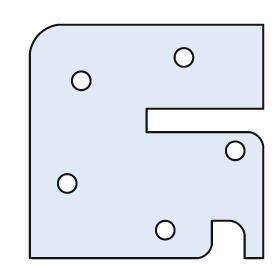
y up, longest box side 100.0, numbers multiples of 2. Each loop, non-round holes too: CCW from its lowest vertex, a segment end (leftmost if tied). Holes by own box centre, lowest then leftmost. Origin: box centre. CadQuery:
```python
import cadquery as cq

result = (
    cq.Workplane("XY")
    .moveTo(-50.0, -50.0)
    .lineTo(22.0, -50.0)
    .threePointArc((26.0, -48.0), (28.0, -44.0))
    .lineTo(28.0, -34.0)
    .lineTo(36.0, -34.0)
    .threePointArc((40.0, -36.0), (42.0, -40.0))
    .lineTo(42.0, -50.0)
    .lineTo(50.0, -50.0)
    .lineTo(50.0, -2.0)
    .threePointArc((48.0, 2.0), (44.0, 4.0))
    .lineTo(0.0, 4.0)
    .lineTo(0.0, 14.0)
    .lineTo(50.0, 14.0)
    .lineTo(50.0, 50.0)
    .lineTo(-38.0, 50.0)
    .threePointArc((-46.0, 46.0), (-50.0, 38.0))
    .close()
    .moveTo(8.0, -38.0)
    .circle(4.0)
    .moveTo(-34.0, -18.0)
    .circle(4.0)
    .moveTo(38.0, -4.0)
    .circle(4.0)
    .moveTo(-28.0, 26.0)
    .circle(4.0)
    .moveTo(16.0, 36.0)
    .circle(4.0)
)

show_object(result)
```